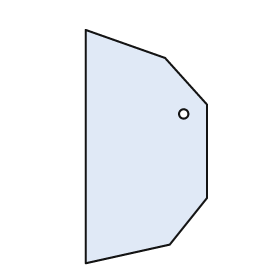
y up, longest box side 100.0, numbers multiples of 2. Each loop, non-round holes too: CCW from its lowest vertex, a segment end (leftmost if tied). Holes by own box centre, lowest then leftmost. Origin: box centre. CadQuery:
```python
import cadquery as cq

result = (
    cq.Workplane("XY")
    .moveTo(-26.0, -50.0)
    .lineTo(10.0, -42.0)
    .lineTo(26.0, -22.0)
    .lineTo(26.0, 18.0)
    .lineTo(8.0, 38.0)
    .lineTo(-26.0, 50.0)
    .close()
    .moveTo(16.0, 14.0)
    .circle(2.0)
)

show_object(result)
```